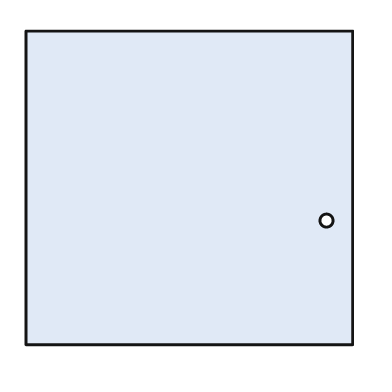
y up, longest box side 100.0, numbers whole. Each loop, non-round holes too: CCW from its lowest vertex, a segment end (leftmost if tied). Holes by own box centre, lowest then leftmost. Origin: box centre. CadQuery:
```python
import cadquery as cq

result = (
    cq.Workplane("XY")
    .moveTo(-50.0, -48.0)
    .lineTo(50.0, -48.0)
    .lineTo(50.0, 48.0)
    .lineTo(-50.0, 48.0)
    .close()
    .moveTo(42.0, -10.0)
    .circle(2.0)
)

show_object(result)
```